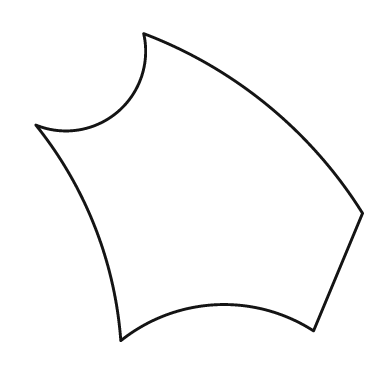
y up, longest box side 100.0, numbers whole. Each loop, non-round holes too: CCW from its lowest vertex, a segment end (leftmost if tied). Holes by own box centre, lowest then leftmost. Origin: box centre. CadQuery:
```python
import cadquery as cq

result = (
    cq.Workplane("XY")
    .moveTo(-24.0, -47.0)
    .threePointArc((5.0, -36.0), (35.0, -44.0))
    .lineTo(50.0, -8.0)
    .threePointArc((21.0, 25.0), (-17.0, 47.0))
    .threePointArc((-25.0, 23.0), (-50.0, 19.0))
    .threePointArc((-32.0, -12.0), (-24.0, -47.0))
    .close()
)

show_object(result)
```